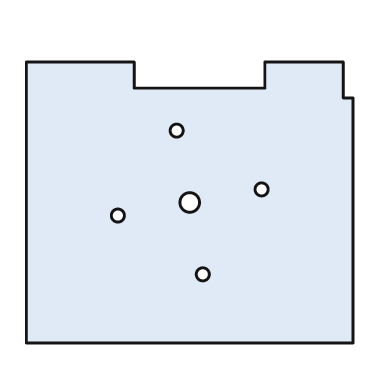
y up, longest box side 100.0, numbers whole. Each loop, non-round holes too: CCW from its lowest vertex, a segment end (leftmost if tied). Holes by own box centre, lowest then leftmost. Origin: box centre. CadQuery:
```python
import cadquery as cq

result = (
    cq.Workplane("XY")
    .moveTo(-50.0, -43.0)
    .lineTo(50.0, -43.0)
    .lineTo(50.0, 32.0)
    .lineTo(47.0, 32.0)
    .lineTo(47.0, 43.0)
    .lineTo(23.0, 43.0)
    .lineTo(23.0, 35.0)
    .lineTo(-17.0, 35.0)
    .lineTo(-17.0, 43.0)
    .lineTo(-50.0, 43.0)
    .close()
    .moveTo(4.0, -22.0)
    .circle(2.0)
    .moveTo(-22.0, -4.0)
    .circle(2.0)
    .moveTo(0.0, 0.0)
    .circle(3.0)
    .moveTo(22.0, 4.0)
    .circle(2.0)
    .moveTo(-4.0, 22.0)
    .circle(2.0)
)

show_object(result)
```